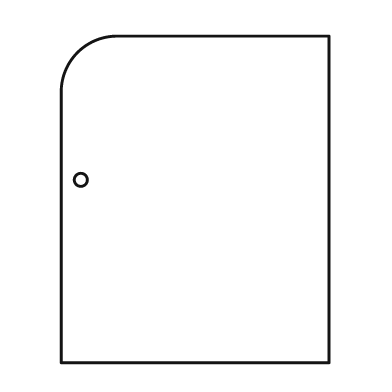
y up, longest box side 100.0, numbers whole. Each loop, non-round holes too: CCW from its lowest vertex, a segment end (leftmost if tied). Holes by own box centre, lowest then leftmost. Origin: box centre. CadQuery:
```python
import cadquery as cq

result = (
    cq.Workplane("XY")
    .moveTo(-41.0, -50.0)
    .lineTo(41.0, -50.0)
    .lineTo(41.0, 50.0)
    .lineTo(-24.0, 50.0)
    .threePointArc((-36.0, 45.0), (-41.0, 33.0))
    .close()
    .moveTo(-35.0, 6.0)
    .circle(2.0)
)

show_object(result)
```